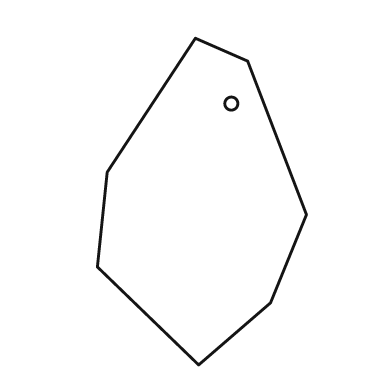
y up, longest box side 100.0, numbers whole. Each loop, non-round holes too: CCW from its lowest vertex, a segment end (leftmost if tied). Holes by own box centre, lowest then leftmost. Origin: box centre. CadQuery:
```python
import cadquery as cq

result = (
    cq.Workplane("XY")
    .moveTo(-1.0, -50.0)
    .lineTo(21.0, -31.0)
    .lineTo(32.0, -4.0)
    .lineTo(14.0, 43.0)
    .lineTo(-2.0, 50.0)
    .lineTo(-29.0, 9.0)
    .lineTo(-32.0, -20.0)
    .close()
    .moveTo(9.0, 30.0)
    .circle(2.0)
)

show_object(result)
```